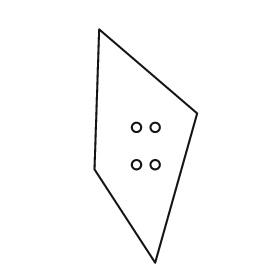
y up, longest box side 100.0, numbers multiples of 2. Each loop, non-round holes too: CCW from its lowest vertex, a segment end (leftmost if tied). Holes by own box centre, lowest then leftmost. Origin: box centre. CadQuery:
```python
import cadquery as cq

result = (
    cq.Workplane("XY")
    .moveTo(4.0, -50.0)
    .lineTo(22.0, 14.0)
    .lineTo(-20.0, 50.0)
    .lineTo(-22.0, -10.0)
    .close()
    .moveTo(-4.0, -8.0)
    .circle(2.0)
    .moveTo(4.0, -8.0)
    .circle(2.0)
    .moveTo(-4.0, 8.0)
    .circle(2.0)
    .moveTo(4.0, 8.0)
    .circle(2.0)
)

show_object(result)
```